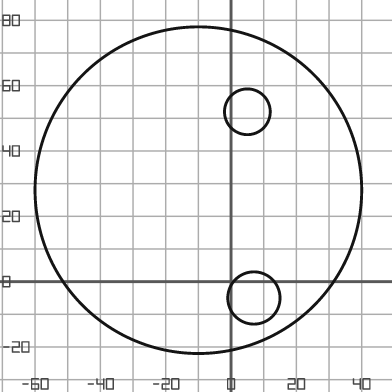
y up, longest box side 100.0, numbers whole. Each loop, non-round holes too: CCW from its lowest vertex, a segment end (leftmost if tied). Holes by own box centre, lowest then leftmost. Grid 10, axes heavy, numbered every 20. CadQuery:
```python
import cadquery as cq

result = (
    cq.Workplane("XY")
    .moveTo(-10.0, 28.0)
    .circle(50.0)
    .moveTo(7.0, -5.0)
    .circle(8.0)
    .moveTo(5.0, 52.0)
    .circle(7.0)
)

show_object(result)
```